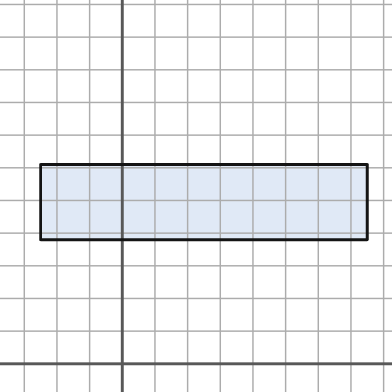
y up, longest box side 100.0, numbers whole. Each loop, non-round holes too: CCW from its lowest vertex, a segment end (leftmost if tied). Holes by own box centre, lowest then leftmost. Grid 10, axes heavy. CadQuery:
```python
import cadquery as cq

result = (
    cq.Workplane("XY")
    .moveTo(-25.0, 38.0)
    .lineTo(75.0, 38.0)
    .lineTo(75.0, 61.0)
    .lineTo(-25.0, 61.0)
    .close()
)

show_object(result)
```